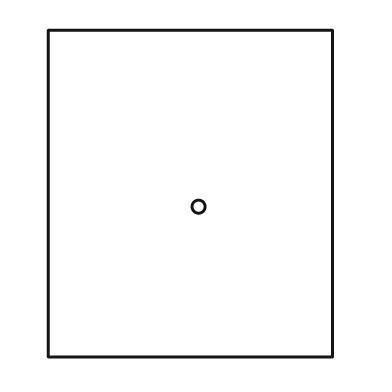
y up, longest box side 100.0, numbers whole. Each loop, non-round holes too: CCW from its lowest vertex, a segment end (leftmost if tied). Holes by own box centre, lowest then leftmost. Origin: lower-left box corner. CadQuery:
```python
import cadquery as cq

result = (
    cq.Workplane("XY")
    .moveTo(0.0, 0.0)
    .lineTo(87.0, 0.0)
    .lineTo(87.0, 100.0)
    .lineTo(0.0, 100.0)
    .close()
    .moveTo(46.0, 46.0)
    .circle(2.0)
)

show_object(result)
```